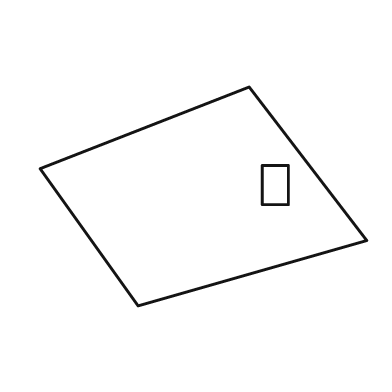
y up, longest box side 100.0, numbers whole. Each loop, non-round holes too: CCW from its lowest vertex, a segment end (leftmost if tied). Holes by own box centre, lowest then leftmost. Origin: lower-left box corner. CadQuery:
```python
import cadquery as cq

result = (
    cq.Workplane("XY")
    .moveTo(30.0, 0.0)
    .lineTo(100.0, 20.0)
    .lineTo(64.0, 67.0)
    .lineTo(0.0, 42.0)
    .close()
    .moveTo(68.0, 31.0)
    .lineTo(76.0, 31.0)
    .lineTo(76.0, 43.0)
    .lineTo(68.0, 43.0)
    .close()
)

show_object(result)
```